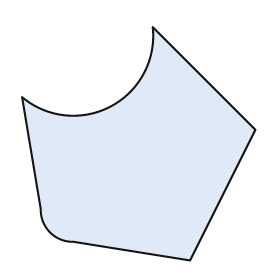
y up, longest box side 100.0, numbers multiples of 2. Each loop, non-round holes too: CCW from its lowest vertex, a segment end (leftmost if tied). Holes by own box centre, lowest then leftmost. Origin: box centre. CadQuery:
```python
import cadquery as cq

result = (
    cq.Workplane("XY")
    .moveTo(22.0, -50.0)
    .lineTo(50.0, 6.0)
    .lineTo(6.0, 50.0)
    .threePointArc((-12.0, 16.0), (-50.0, 20.0))
    .lineTo(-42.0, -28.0)
    .threePointArc((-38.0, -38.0), (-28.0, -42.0))
    .close()
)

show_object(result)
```